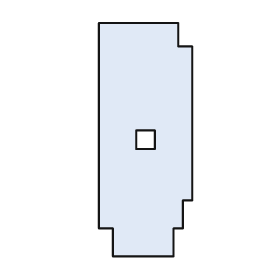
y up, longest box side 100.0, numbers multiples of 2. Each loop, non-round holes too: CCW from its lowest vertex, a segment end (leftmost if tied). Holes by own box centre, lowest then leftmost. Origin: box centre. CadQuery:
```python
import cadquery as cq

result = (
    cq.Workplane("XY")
    .moveTo(-14.0, -50.0)
    .lineTo(12.0, -50.0)
    .lineTo(12.0, -38.0)
    .lineTo(16.0, -38.0)
    .lineTo(16.0, -26.0)
    .lineTo(20.0, -26.0)
    .lineTo(20.0, 40.0)
    .lineTo(14.0, 40.0)
    .lineTo(14.0, 50.0)
    .lineTo(-20.0, 50.0)
    .lineTo(-20.0, -38.0)
    .lineTo(-14.0, -38.0)
    .close()
    .moveTo(-4.0, -4.0)
    .lineTo(4.0, -4.0)
    .lineTo(4.0, 4.0)
    .lineTo(-4.0, 4.0)
    .close()
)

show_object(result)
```